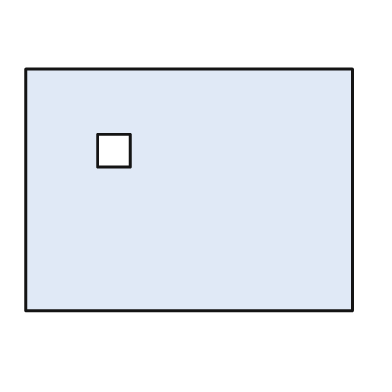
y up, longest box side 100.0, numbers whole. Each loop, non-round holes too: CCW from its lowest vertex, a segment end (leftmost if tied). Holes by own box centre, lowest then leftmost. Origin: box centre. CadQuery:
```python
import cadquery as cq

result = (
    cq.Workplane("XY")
    .moveTo(-50.0, -37.0)
    .lineTo(50.0, -37.0)
    .lineTo(50.0, 37.0)
    .lineTo(-50.0, 37.0)
    .close()
    .moveTo(-28.0, 7.0)
    .lineTo(-18.0, 7.0)
    .lineTo(-18.0, 17.0)
    .lineTo(-28.0, 17.0)
    .close()
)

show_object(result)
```